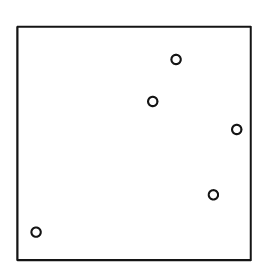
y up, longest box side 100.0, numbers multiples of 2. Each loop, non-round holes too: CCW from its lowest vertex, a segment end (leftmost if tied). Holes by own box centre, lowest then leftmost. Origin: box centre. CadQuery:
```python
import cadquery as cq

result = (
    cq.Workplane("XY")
    .moveTo(-50.0, -50.0)
    .lineTo(50.0, -50.0)
    .lineTo(50.0, 50.0)
    .lineTo(-50.0, 50.0)
    .close()
    .moveTo(-42.0, -38.0)
    .circle(2.0)
    .moveTo(34.0, -22.0)
    .circle(2.0)
    .moveTo(44.0, 6.0)
    .circle(2.0)
    .moveTo(8.0, 18.0)
    .circle(2.0)
    .moveTo(18.0, 36.0)
    .circle(2.0)
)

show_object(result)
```